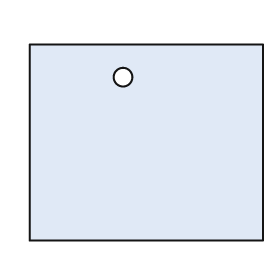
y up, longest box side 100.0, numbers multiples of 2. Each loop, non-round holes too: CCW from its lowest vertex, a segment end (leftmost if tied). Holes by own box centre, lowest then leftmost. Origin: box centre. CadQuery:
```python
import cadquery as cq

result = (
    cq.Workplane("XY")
    .moveTo(-50.0, -42.0)
    .lineTo(50.0, -42.0)
    .lineTo(50.0, 42.0)
    .lineTo(-50.0, 42.0)
    .close()
    .moveTo(-10.0, 28.0)
    .circle(4.0)
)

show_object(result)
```